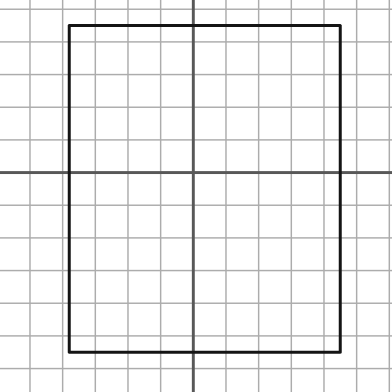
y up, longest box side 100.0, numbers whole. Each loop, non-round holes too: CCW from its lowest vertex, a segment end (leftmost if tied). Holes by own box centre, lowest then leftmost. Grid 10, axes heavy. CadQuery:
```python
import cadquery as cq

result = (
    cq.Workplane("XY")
    .moveTo(-38.0, -55.0)
    .lineTo(45.0, -55.0)
    .lineTo(45.0, 45.0)
    .lineTo(-38.0, 45.0)
    .close()
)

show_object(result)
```